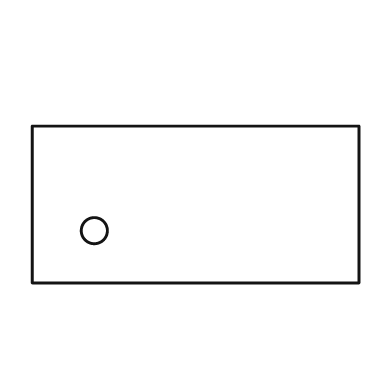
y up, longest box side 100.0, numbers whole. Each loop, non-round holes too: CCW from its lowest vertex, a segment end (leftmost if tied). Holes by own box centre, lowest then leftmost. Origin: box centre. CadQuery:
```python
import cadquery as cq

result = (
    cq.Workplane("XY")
    .moveTo(-50.0, -24.0)
    .lineTo(50.0, -24.0)
    .lineTo(50.0, 24.0)
    .lineTo(-50.0, 24.0)
    .close()
    .moveTo(-31.0, -8.0)
    .circle(4.0)
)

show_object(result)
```